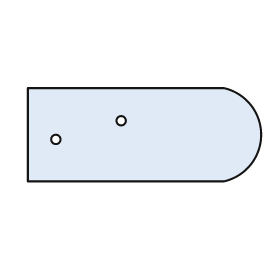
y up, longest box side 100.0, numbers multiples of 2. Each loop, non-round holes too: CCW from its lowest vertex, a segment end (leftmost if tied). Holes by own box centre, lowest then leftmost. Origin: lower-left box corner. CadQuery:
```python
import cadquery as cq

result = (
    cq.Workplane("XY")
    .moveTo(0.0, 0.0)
    .lineTo(84.0, 0.0)
    .threePointArc((100.0, 20.0), (84.0, 40.0))
    .lineTo(0.0, 40.0)
    .close()
    .moveTo(12.0, 18.0)
    .circle(2.0)
    .moveTo(40.0, 26.0)
    .circle(2.0)
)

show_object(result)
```